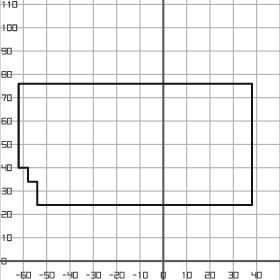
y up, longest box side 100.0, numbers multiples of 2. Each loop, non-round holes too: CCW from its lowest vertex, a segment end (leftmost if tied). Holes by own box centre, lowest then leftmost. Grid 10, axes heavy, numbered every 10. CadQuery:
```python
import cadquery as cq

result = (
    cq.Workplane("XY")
    .moveTo(-54.0, 24.0)
    .lineTo(38.0, 24.0)
    .lineTo(38.0, 76.0)
    .lineTo(-62.0, 76.0)
    .lineTo(-62.0, 40.0)
    .lineTo(-58.0, 40.0)
    .lineTo(-58.0, 34.0)
    .lineTo(-54.0, 34.0)
    .close()
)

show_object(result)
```